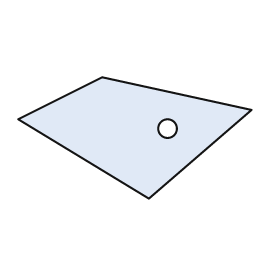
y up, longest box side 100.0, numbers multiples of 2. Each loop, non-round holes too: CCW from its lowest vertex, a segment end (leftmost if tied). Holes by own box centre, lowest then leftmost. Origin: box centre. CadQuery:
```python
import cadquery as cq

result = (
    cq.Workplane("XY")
    .moveTo(6.0, -26.0)
    .lineTo(50.0, 12.0)
    .lineTo(-14.0, 26.0)
    .lineTo(-50.0, 8.0)
    .close()
    .moveTo(14.0, 4.0)
    .circle(4.0)
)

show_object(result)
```